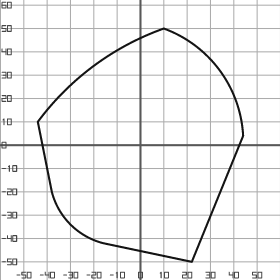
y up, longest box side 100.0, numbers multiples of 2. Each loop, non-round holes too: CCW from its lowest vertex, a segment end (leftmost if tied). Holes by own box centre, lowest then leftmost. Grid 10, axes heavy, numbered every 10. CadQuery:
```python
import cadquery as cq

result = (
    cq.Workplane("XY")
    .moveTo(22.0, -50.0)
    .lineTo(44.0, 4.0)
    .threePointArc((34.0, 32.0), (10.0, 50.0))
    .threePointArc((-20.0, 34.0), (-44.0, 10.0))
    .lineTo(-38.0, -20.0)
    .threePointArc((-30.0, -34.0), (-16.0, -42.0))
    .close()
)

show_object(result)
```